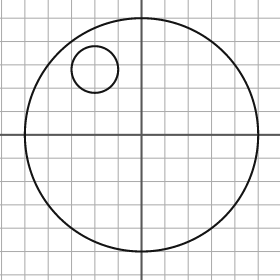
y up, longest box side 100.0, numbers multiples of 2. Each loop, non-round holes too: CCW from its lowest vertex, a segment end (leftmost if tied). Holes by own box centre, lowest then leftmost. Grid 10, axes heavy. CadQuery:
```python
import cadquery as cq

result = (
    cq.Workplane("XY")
    .moveTo(0.0, 0.0)
    .circle(50.0)
    .moveTo(-20.0, 28.0)
    .circle(10.0)
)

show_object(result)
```